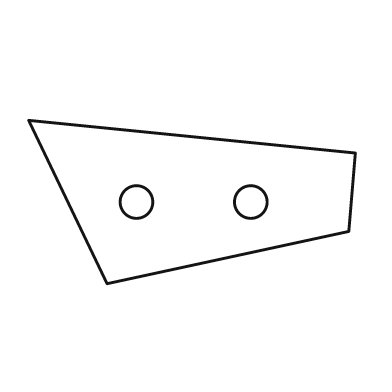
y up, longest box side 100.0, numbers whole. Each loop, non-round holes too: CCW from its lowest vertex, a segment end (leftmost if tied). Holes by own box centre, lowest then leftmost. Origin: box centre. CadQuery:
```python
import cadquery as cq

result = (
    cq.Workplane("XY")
    .moveTo(-26.0, -25.0)
    .lineTo(48.0, -9.0)
    .lineTo(50.0, 15.0)
    .lineTo(-50.0, 25.0)
    .close()
    .moveTo(-17.0, 0.0)
    .circle(5.0)
    .moveTo(18.0, 0.0)
    .circle(5.0)
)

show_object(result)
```